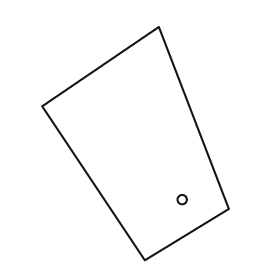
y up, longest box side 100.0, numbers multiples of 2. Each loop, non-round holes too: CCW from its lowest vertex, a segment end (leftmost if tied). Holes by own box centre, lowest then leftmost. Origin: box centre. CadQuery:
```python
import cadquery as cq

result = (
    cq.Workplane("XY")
    .moveTo(4.0, -50.0)
    .lineTo(40.0, -28.0)
    .lineTo(10.0, 50.0)
    .lineTo(-40.0, 16.0)
    .close()
    .moveTo(20.0, -24.0)
    .circle(2.0)
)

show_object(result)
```